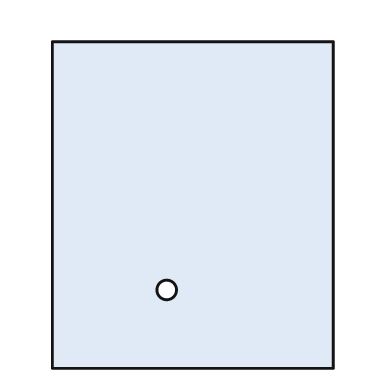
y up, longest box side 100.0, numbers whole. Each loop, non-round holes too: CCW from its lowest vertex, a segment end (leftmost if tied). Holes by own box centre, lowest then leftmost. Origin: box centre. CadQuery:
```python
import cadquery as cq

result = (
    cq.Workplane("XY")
    .moveTo(-43.0, -50.0)
    .lineTo(43.0, -50.0)
    .lineTo(43.0, 50.0)
    .lineTo(-43.0, 50.0)
    .close()
    .moveTo(-8.0, -26.0)
    .circle(3.0)
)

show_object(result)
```